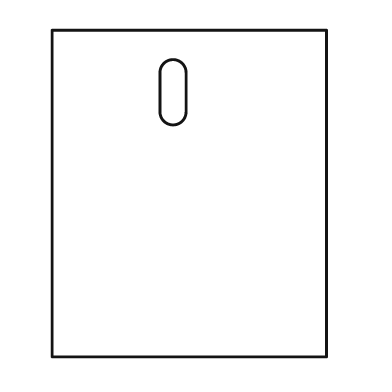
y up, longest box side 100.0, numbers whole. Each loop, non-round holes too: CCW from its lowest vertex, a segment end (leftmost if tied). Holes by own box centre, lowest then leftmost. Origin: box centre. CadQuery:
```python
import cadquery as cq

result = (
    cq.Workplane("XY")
    .moveTo(-42.0, -50.0)
    .lineTo(42.0, -50.0)
    .lineTo(42.0, 50.0)
    .lineTo(-42.0, 50.0)
    .close()
    .moveTo(-9.0, 25.0)
    .threePointArc((-5.0, 21.0), (-1.0, 25.0))
    .lineTo(-1.0, 37.0)
    .threePointArc((-5.0, 41.0), (-9.0, 37.0))
    .close()
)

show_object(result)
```